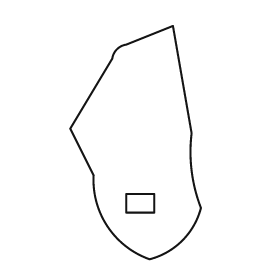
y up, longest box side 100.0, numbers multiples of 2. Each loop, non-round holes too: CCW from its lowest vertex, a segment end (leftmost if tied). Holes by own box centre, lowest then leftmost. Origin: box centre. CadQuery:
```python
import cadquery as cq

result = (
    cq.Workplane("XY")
    .moveTo(6.0, -50.0)
    .threePointArc((20.0, -42.0), (28.0, -28.0))
    .threePointArc((24.0, -12.0), (24.0, 4.0))
    .lineTo(16.0, 50.0)
    .lineTo(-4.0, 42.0)
    .threePointArc((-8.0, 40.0), (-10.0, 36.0))
    .lineTo(-28.0, 6.0)
    .lineTo(-18.0, -14.0)
    .threePointArc((-12.0, -36.0), (6.0, -50.0))
    .close()
    .moveTo(-4.0, -30.0)
    .lineTo(8.0, -30.0)
    .lineTo(8.0, -22.0)
    .lineTo(-4.0, -22.0)
    .close()
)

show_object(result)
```